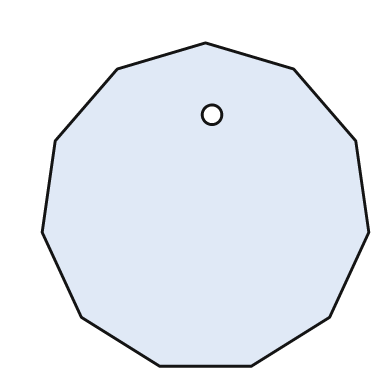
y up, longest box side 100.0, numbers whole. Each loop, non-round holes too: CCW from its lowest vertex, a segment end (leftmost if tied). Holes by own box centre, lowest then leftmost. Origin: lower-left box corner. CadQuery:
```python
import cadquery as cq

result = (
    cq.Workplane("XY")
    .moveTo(36.0, 0.0)
    .lineTo(64.0, 0.0)
    .lineTo(88.0, 15.0)
    .lineTo(100.0, 41.0)
    .lineTo(96.0, 69.0)
    .lineTo(77.0, 91.0)
    .lineTo(50.0, 99.0)
    .lineTo(23.0, 91.0)
    .lineTo(4.0, 69.0)
    .lineTo(0.0, 41.0)
    .lineTo(12.0, 15.0)
    .close()
    .moveTo(52.0, 77.0)
    .circle(3.0)
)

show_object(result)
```